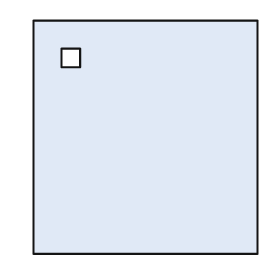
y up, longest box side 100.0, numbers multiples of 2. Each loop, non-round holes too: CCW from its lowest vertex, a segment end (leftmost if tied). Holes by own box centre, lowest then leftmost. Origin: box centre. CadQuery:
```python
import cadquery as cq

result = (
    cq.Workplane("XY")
    .moveTo(-48.0, -50.0)
    .lineTo(48.0, -50.0)
    .lineTo(48.0, 50.0)
    .lineTo(-48.0, 50.0)
    .close()
    .moveTo(-36.0, 30.0)
    .lineTo(-28.0, 30.0)
    .lineTo(-28.0, 38.0)
    .lineTo(-36.0, 38.0)
    .close()
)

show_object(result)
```